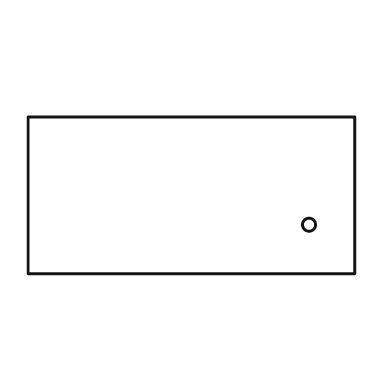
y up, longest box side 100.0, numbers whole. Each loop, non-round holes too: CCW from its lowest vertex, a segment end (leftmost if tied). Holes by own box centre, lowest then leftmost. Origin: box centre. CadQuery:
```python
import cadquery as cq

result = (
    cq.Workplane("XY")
    .moveTo(-50.0, -24.0)
    .lineTo(50.0, -24.0)
    .lineTo(50.0, 24.0)
    .lineTo(-50.0, 24.0)
    .close()
    .moveTo(36.0, -9.0)
    .circle(2.0)
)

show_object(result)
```